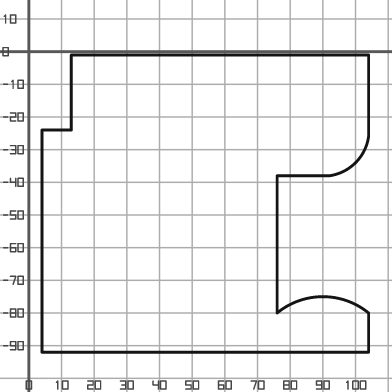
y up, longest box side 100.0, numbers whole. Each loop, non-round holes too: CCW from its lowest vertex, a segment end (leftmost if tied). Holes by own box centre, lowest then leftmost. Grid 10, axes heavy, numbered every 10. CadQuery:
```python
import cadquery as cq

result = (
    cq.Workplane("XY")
    .moveTo(4.0, -92.0)
    .lineTo(104.0, -92.0)
    .lineTo(104.0, -80.0)
    .threePointArc((90.0, -75.0), (76.0, -80.0))
    .lineTo(76.0, -38.0)
    .lineTo(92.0, -38.0)
    .threePointArc((100.0, -34.0), (104.0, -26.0))
    .lineTo(104.0, -1.0)
    .lineTo(13.0, -1.0)
    .lineTo(13.0, -24.0)
    .lineTo(4.0, -24.0)
    .close()
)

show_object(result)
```